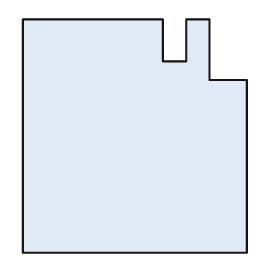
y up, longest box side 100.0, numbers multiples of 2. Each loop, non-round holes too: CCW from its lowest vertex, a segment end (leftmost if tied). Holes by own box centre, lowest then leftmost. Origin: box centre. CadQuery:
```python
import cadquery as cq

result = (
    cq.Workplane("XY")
    .moveTo(-48.0, -50.0)
    .lineTo(48.0, -50.0)
    .lineTo(48.0, 24.0)
    .lineTo(32.0, 24.0)
    .lineTo(32.0, 50.0)
    .lineTo(22.0, 50.0)
    .lineTo(22.0, 32.0)
    .lineTo(12.0, 32.0)
    .lineTo(12.0, 50.0)
    .lineTo(-48.0, 50.0)
    .close()
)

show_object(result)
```